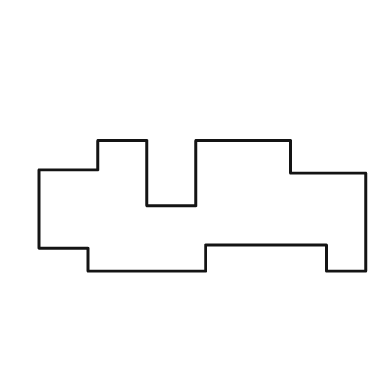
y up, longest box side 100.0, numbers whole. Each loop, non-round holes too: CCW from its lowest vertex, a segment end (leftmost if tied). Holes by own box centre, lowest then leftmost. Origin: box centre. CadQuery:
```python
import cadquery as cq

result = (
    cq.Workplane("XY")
    .moveTo(-35.0, -20.0)
    .lineTo(1.0, -20.0)
    .lineTo(1.0, -12.0)
    .lineTo(38.0, -12.0)
    .lineTo(38.0, -20.0)
    .lineTo(50.0, -20.0)
    .lineTo(50.0, 10.0)
    .lineTo(27.0, 10.0)
    .lineTo(27.0, 20.0)
    .lineTo(-2.0, 20.0)
    .lineTo(-2.0, 0.0)
    .lineTo(-17.0, 0.0)
    .lineTo(-17.0, 20.0)
    .lineTo(-32.0, 20.0)
    .lineTo(-32.0, 11.0)
    .lineTo(-50.0, 11.0)
    .lineTo(-50.0, -13.0)
    .lineTo(-35.0, -13.0)
    .close()
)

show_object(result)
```